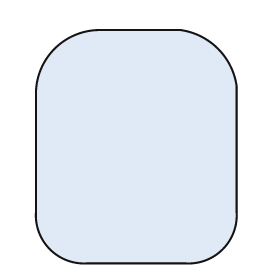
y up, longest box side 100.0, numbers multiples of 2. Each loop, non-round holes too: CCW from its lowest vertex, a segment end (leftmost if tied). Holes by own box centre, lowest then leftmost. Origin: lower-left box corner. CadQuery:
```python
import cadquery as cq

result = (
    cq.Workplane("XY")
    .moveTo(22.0, 0.0)
    .lineTo(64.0, 0.0)
    .threePointArc((80.0, 6.0), (86.0, 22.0))
    .lineTo(86.0, 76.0)
    .threePointArc((78.0, 92.0), (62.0, 100.0))
    .lineTo(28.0, 100.0)
    .threePointArc((8.0, 92.0), (0.0, 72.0))
    .lineTo(0.0, 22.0)
    .threePointArc((6.0, 6.0), (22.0, 0.0))
    .close()
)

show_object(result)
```